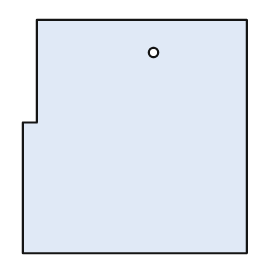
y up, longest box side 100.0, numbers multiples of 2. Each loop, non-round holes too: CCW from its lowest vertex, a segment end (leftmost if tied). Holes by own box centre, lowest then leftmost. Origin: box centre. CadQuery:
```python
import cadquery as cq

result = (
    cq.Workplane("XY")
    .moveTo(-48.0, -50.0)
    .lineTo(48.0, -50.0)
    .lineTo(48.0, 50.0)
    .lineTo(-42.0, 50.0)
    .lineTo(-42.0, 6.0)
    .lineTo(-48.0, 6.0)
    .close()
    .moveTo(8.0, 36.0)
    .circle(2.0)
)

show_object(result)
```